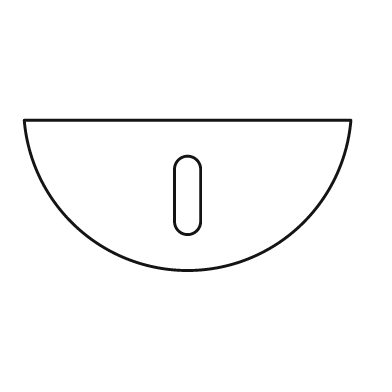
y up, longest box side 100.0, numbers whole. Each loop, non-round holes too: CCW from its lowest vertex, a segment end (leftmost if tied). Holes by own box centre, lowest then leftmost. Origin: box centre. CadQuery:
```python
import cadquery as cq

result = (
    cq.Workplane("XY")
    .moveTo(-50.0, 23.0)
    .threePointArc((0.0, -23.0), (50.0, 23.0))
    .close()
    .moveTo(-4.0, -8.0)
    .threePointArc((0.0, -12.0), (4.0, -8.0))
    .lineTo(4.0, 8.0)
    .threePointArc((0.0, 12.0), (-4.0, 8.0))
    .close()
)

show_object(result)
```